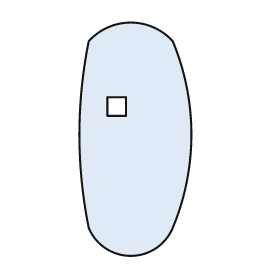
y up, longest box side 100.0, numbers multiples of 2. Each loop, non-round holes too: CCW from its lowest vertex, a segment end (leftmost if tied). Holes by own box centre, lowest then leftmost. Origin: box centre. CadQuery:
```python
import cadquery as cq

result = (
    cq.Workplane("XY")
    .moveTo(-20.0, -38.0)
    .threePointArc((-2.0, -50.0), (16.0, -38.0))
    .threePointArc((24.0, 2.0), (16.0, 42.0))
    .threePointArc((-2.0, 50.0), (-20.0, 42.0))
    .threePointArc((-24.0, 2.0), (-20.0, -38.0))
    .close()
    .moveTo(-12.0, 10.0)
    .lineTo(-4.0, 10.0)
    .lineTo(-4.0, 18.0)
    .lineTo(-12.0, 18.0)
    .close()
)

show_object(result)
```